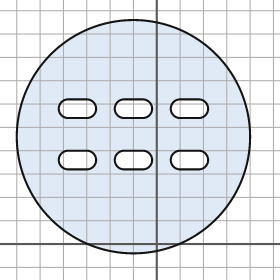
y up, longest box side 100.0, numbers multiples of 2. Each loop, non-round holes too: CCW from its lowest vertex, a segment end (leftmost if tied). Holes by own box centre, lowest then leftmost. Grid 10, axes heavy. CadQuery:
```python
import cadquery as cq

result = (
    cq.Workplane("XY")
    .moveTo(-10.0, 46.0)
    .circle(50.0)
    .moveTo(-38.0, 32.0)
    .lineTo(-30.0, 32.0)
    .threePointArc((-26.0, 36.0), (-30.0, 40.0))
    .lineTo(-38.0, 40.0)
    .threePointArc((-42.0, 36.0), (-38.0, 32.0))
    .close()
    .moveTo(-14.0, 32.0)
    .lineTo(-6.0, 32.0)
    .threePointArc((-2.0, 36.0), (-6.0, 40.0))
    .lineTo(-14.0, 40.0)
    .threePointArc((-18.0, 36.0), (-14.0, 32.0))
    .close()
    .moveTo(10.0, 32.0)
    .lineTo(18.0, 32.0)
    .threePointArc((22.0, 36.0), (18.0, 40.0))
    .lineTo(10.0, 40.0)
    .threePointArc((6.0, 36.0), (10.0, 32.0))
    .close()
    .moveTo(-38.0, 54.0)
    .lineTo(-30.0, 54.0)
    .threePointArc((-26.0, 58.0), (-30.0, 62.0))
    .lineTo(-38.0, 62.0)
    .threePointArc((-42.0, 58.0), (-38.0, 54.0))
    .close()
    .moveTo(-14.0, 54.0)
    .lineTo(-6.0, 54.0)
    .threePointArc((-2.0, 58.0), (-6.0, 62.0))
    .lineTo(-14.0, 62.0)
    .threePointArc((-18.0, 58.0), (-14.0, 54.0))
    .close()
    .moveTo(10.0, 54.0)
    .lineTo(18.0, 54.0)
    .threePointArc((22.0, 58.0), (18.0, 62.0))
    .lineTo(10.0, 62.0)
    .threePointArc((6.0, 58.0), (10.0, 54.0))
    .close()
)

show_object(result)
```